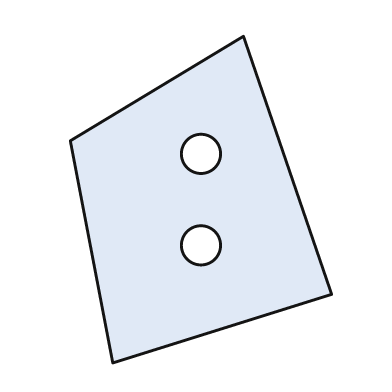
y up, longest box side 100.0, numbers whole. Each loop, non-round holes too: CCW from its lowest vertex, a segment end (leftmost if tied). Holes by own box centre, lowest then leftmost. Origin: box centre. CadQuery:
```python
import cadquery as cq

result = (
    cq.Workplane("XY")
    .moveTo(-27.0, -50.0)
    .lineTo(40.0, -29.0)
    .lineTo(13.0, 50.0)
    .lineTo(-40.0, 18.0)
    .close()
    .moveTo(0.0, -14.0)
    .circle(6.0)
    .moveTo(0.0, 14.0)
    .circle(6.0)
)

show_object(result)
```